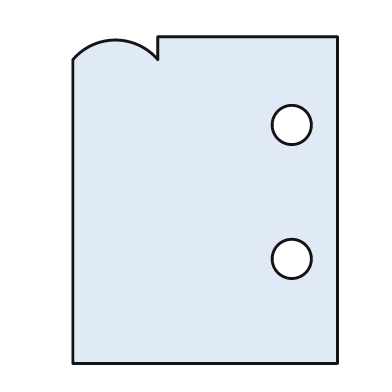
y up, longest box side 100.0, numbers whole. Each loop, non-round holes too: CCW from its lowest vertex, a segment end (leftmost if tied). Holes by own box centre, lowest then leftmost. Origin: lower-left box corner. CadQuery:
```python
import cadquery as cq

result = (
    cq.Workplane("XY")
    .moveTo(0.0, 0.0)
    .lineTo(81.0, 0.0)
    .lineTo(81.0, 100.0)
    .lineTo(26.0, 100.0)
    .lineTo(26.0, 93.0)
    .threePointArc((13.0, 99.0), (0.0, 93.0))
    .close()
    .moveTo(67.0, 32.0)
    .circle(6.0)
    .moveTo(67.0, 73.0)
    .circle(6.0)
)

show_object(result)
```